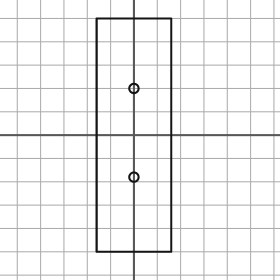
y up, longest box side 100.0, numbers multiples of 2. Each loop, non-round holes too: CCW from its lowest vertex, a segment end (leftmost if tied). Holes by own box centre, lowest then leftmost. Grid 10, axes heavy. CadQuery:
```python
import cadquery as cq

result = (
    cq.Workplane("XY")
    .moveTo(-16.0, -50.0)
    .lineTo(16.0, -50.0)
    .lineTo(16.0, 50.0)
    .lineTo(-16.0, 50.0)
    .close()
    .moveTo(0.0, -18.0)
    .circle(2.0)
    .moveTo(0.0, 20.0)
    .circle(2.0)
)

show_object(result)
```